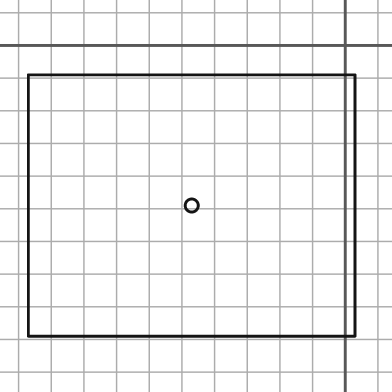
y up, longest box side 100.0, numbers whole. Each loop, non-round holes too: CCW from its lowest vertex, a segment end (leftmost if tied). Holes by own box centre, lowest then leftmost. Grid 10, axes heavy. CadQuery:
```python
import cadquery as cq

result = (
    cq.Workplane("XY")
    .moveTo(-97.0, -89.0)
    .lineTo(3.0, -89.0)
    .lineTo(3.0, -9.0)
    .lineTo(-97.0, -9.0)
    .close()
    .moveTo(-47.0, -49.0)
    .circle(2.0)
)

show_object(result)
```